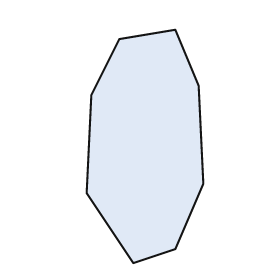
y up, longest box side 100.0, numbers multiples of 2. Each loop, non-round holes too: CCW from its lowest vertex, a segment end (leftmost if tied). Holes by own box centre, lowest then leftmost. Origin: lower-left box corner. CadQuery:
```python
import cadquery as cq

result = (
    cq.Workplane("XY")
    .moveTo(20.0, 0.0)
    .lineTo(38.0, 6.0)
    .lineTo(50.0, 34.0)
    .lineTo(48.0, 76.0)
    .lineTo(38.0, 100.0)
    .lineTo(14.0, 96.0)
    .lineTo(2.0, 72.0)
    .lineTo(0.0, 30.0)
    .close()
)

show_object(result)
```